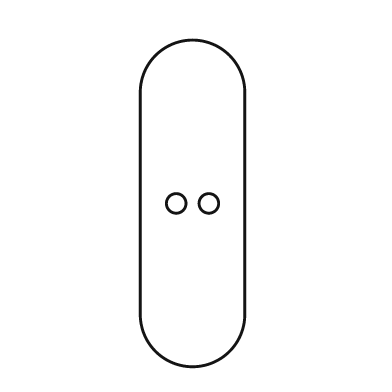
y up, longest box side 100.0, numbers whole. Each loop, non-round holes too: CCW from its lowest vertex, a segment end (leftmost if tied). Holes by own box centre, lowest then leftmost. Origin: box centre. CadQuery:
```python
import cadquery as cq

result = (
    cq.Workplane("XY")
    .moveTo(-16.0, -34.0)
    .threePointArc((0.0, -50.0), (16.0, -34.0))
    .lineTo(16.0, 34.0)
    .threePointArc((0.0, 50.0), (-16.0, 34.0))
    .close()
    .moveTo(-5.0, 0.0)
    .circle(3.0)
    .moveTo(5.0, 0.0)
    .circle(3.0)
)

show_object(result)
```